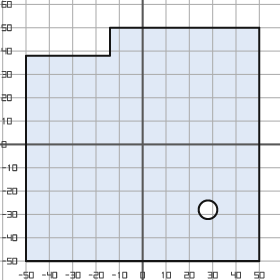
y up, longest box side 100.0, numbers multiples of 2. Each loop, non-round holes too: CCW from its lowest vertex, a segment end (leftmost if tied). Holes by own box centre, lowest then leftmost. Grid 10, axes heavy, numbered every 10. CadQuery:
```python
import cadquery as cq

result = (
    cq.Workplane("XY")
    .moveTo(-50.0, -50.0)
    .lineTo(50.0, -50.0)
    .lineTo(50.0, 50.0)
    .lineTo(-14.0, 50.0)
    .lineTo(-14.0, 38.0)
    .lineTo(-50.0, 38.0)
    .close()
    .moveTo(28.0, -28.0)
    .circle(4.0)
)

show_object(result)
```